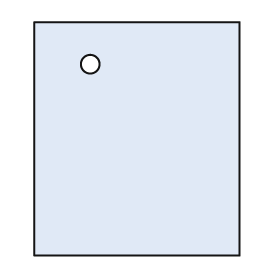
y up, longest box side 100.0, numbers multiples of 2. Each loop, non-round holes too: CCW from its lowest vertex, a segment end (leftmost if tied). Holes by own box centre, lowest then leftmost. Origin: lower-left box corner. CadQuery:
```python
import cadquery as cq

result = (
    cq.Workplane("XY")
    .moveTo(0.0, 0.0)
    .lineTo(88.0, 0.0)
    .lineTo(88.0, 100.0)
    .lineTo(0.0, 100.0)
    .close()
    .moveTo(24.0, 82.0)
    .circle(4.0)
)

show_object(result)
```